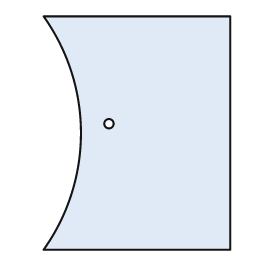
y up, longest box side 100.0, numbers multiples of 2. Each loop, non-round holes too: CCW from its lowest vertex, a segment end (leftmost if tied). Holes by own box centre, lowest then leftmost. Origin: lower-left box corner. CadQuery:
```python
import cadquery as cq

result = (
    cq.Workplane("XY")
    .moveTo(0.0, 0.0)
    .lineTo(80.0, 0.0)
    .lineTo(80.0, 100.0)
    .lineTo(0.0, 100.0)
    .threePointArc((16.0, 50.0), (0.0, 0.0))
    .close()
    .moveTo(28.0, 54.0)
    .circle(2.0)
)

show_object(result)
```